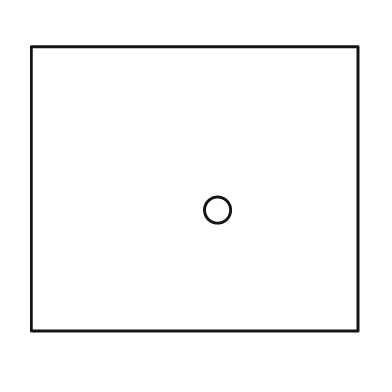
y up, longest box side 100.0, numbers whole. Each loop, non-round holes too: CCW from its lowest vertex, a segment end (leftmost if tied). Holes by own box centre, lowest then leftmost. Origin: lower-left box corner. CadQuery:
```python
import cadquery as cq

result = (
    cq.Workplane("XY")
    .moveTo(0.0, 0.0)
    .lineTo(100.0, 0.0)
    .lineTo(100.0, 87.0)
    .lineTo(0.0, 87.0)
    .close()
    .moveTo(57.0, 37.0)
    .circle(4.0)
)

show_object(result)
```